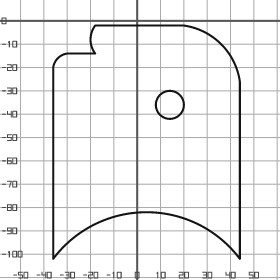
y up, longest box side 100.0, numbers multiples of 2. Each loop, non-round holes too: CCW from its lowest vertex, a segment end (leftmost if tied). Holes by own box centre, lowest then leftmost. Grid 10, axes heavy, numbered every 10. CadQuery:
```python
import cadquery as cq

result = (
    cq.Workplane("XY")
    .moveTo(-36.0, -102.0)
    .threePointArc((4.0, -82.0), (44.0, -102.0))
    .lineTo(44.0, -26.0)
    .threePointArc((36.0, -10.0), (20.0, -2.0))
    .lineTo(-18.0, -2.0)
    .threePointArc((-20.0, -8.0), (-18.0, -14.0))
    .lineTo(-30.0, -14.0)
    .threePointArc((-34.0, -16.0), (-36.0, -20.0))
    .close()
    .moveTo(14.0, -36.0)
    .circle(6.0)
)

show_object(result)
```